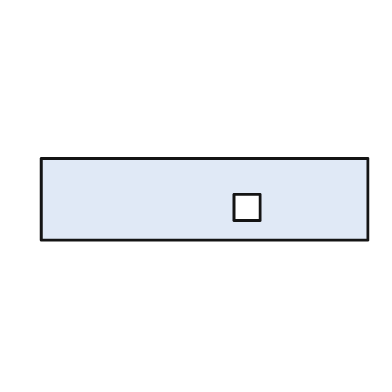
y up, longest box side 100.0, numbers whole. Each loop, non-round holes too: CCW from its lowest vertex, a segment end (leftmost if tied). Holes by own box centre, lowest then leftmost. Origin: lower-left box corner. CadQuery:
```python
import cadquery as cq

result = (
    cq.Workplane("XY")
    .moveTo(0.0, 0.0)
    .lineTo(100.0, 0.0)
    .lineTo(100.0, 25.0)
    .lineTo(0.0, 25.0)
    .close()
    .moveTo(59.0, 6.0)
    .lineTo(67.0, 6.0)
    .lineTo(67.0, 14.0)
    .lineTo(59.0, 14.0)
    .close()
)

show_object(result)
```